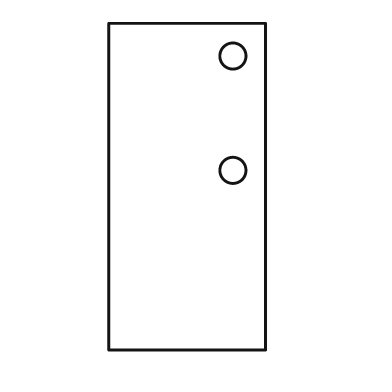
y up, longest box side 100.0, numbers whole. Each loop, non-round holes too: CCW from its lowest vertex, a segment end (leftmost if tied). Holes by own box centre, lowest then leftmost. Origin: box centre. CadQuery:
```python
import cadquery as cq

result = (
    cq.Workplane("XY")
    .moveTo(-24.0, -50.0)
    .lineTo(24.0, -50.0)
    .lineTo(24.0, 50.0)
    .lineTo(-24.0, 50.0)
    .close()
    .moveTo(14.0, 5.0)
    .circle(4.0)
    .moveTo(14.0, 40.0)
    .circle(4.0)
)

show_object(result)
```